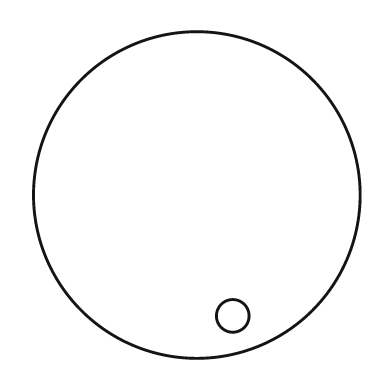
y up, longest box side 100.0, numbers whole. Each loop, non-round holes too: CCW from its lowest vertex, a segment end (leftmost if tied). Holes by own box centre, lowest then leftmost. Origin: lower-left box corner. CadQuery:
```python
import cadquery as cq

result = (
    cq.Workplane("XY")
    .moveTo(50.0, 50.0)
    .circle(50.0)
    .moveTo(61.0, 13.0)
    .circle(5.0)
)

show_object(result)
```